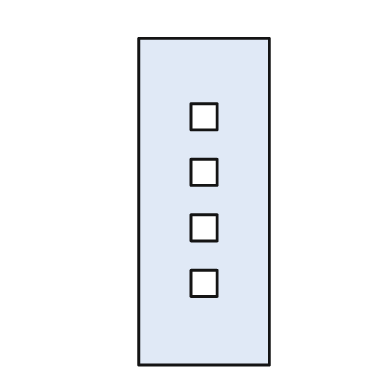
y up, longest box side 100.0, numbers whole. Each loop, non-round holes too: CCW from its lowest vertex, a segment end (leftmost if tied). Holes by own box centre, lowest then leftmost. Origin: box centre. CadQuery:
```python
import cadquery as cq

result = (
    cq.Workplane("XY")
    .moveTo(-20.0, -50.0)
    .lineTo(20.0, -50.0)
    .lineTo(20.0, 50.0)
    .lineTo(-20.0, 50.0)
    .close()
    .moveTo(-4.0, -29.0)
    .lineTo(4.0, -29.0)
    .lineTo(4.0, -21.0)
    .lineTo(-4.0, -21.0)
    .close()
    .moveTo(-4.0, -12.0)
    .lineTo(4.0, -12.0)
    .lineTo(4.0, -4.0)
    .lineTo(-4.0, -4.0)
    .close()
    .moveTo(-4.0, 5.0)
    .lineTo(4.0, 5.0)
    .lineTo(4.0, 13.0)
    .lineTo(-4.0, 13.0)
    .close()
    .moveTo(-4.0, 22.0)
    .lineTo(4.0, 22.0)
    .lineTo(4.0, 30.0)
    .lineTo(-4.0, 30.0)
    .close()
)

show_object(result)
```